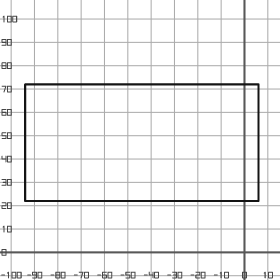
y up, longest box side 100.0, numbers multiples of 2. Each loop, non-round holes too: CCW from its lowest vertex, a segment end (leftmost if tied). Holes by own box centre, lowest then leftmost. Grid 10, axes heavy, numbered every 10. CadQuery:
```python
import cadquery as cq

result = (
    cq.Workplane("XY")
    .moveTo(-94.0, 22.0)
    .lineTo(6.0, 22.0)
    .lineTo(6.0, 72.0)
    .lineTo(-94.0, 72.0)
    .close()
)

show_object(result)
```